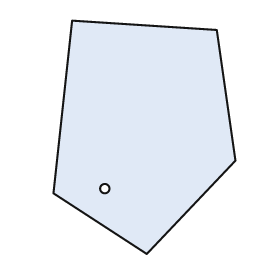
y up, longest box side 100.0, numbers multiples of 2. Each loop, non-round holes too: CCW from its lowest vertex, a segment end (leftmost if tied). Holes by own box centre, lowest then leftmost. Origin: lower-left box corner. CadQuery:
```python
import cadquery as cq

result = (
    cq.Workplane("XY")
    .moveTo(40.0, 0.0)
    .lineTo(78.0, 40.0)
    .lineTo(70.0, 96.0)
    .lineTo(8.0, 100.0)
    .lineTo(0.0, 26.0)
    .close()
    .moveTo(22.0, 28.0)
    .circle(2.0)
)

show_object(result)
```